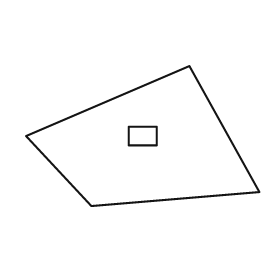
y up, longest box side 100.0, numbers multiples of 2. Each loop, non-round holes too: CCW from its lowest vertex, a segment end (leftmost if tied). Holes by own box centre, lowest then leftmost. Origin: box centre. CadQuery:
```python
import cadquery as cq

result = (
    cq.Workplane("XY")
    .moveTo(-22.0, -30.0)
    .lineTo(50.0, -24.0)
    .lineTo(20.0, 30.0)
    .lineTo(-50.0, 0.0)
    .close()
    .moveTo(-6.0, -4.0)
    .lineTo(6.0, -4.0)
    .lineTo(6.0, 4.0)
    .lineTo(-6.0, 4.0)
    .close()
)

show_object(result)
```